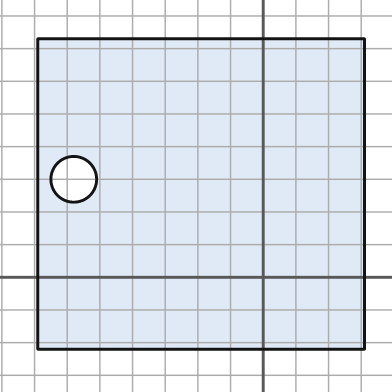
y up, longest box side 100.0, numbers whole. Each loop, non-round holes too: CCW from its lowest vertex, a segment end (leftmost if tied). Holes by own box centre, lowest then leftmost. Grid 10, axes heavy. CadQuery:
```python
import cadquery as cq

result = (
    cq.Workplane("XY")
    .moveTo(-69.0, -22.0)
    .lineTo(31.0, -22.0)
    .lineTo(31.0, 73.0)
    .lineTo(-69.0, 73.0)
    .close()
    .moveTo(-58.0, 30.0)
    .circle(7.0)
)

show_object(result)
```